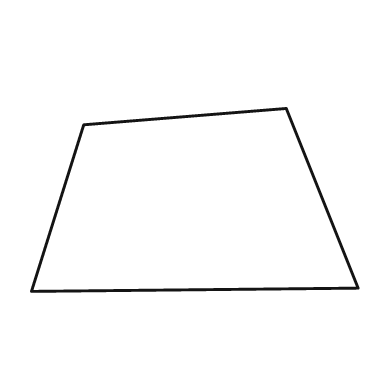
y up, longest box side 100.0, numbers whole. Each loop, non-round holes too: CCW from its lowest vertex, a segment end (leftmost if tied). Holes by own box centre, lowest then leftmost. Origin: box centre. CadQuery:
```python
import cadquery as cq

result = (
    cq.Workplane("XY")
    .moveTo(-50.0, -28.0)
    .lineTo(50.0, -27.0)
    .lineTo(28.0, 28.0)
    .lineTo(-34.0, 23.0)
    .close()
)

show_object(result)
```